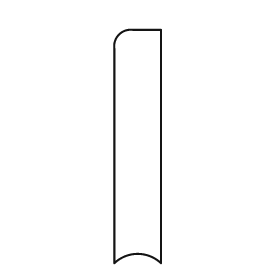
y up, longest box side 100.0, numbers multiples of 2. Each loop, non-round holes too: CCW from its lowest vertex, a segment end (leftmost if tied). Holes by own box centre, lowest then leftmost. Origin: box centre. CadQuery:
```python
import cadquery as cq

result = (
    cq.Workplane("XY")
    .moveTo(-10.0, -50.0)
    .threePointArc((0.0, -46.0), (10.0, -50.0))
    .lineTo(10.0, 50.0)
    .lineTo(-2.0, 50.0)
    .threePointArc((-8.0, 48.0), (-10.0, 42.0))
    .close()
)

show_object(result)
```